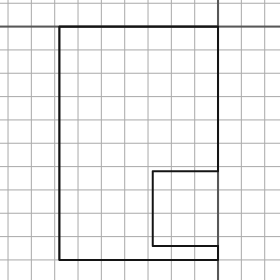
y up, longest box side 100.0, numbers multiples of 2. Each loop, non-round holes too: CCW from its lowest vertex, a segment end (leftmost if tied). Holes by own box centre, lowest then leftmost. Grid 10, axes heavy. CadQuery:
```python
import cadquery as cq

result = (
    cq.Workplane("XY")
    .moveTo(-68.0, -100.0)
    .lineTo(0.0, -100.0)
    .lineTo(0.0, -94.0)
    .lineTo(-28.0, -94.0)
    .lineTo(-28.0, -62.0)
    .lineTo(0.0, -62.0)
    .lineTo(0.0, 0.0)
    .lineTo(-68.0, 0.0)
    .close()
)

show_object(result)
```